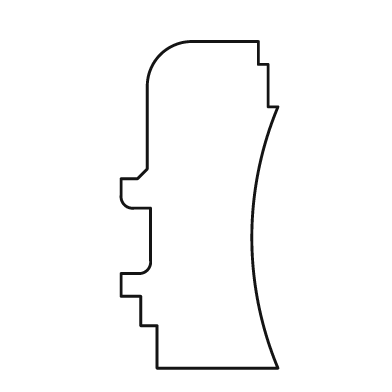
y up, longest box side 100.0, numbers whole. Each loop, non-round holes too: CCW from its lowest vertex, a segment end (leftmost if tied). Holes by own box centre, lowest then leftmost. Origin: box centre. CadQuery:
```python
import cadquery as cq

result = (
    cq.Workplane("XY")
    .moveTo(-13.0, -50.0)
    .lineTo(24.0, -50.0)
    .threePointArc((16.0, -10.0), (24.0, 30.0))
    .lineTo(21.0, 30.0)
    .lineTo(21.0, 43.0)
    .lineTo(18.0, 43.0)
    .lineTo(18.0, 50.0)
    .lineTo(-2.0, 50.0)
    .threePointArc((-12.0, 46.0), (-16.0, 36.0))
    .lineTo(-16.0, 11.0)
    .lineTo(-19.0, 8.0)
    .lineTo(-24.0, 8.0)
    .lineTo(-24.0, 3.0)
    .threePointArc((-23.0, 0.0), (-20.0, -1.0))
    .lineTo(-15.0, -1.0)
    .lineTo(-15.0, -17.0)
    .threePointArc((-16.0, -20.0), (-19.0, -21.0))
    .lineTo(-24.0, -21.0)
    .lineTo(-24.0, -28.0)
    .lineTo(-18.0, -28.0)
    .lineTo(-18.0, -37.0)
    .lineTo(-13.0, -37.0)
    .close()
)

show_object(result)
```